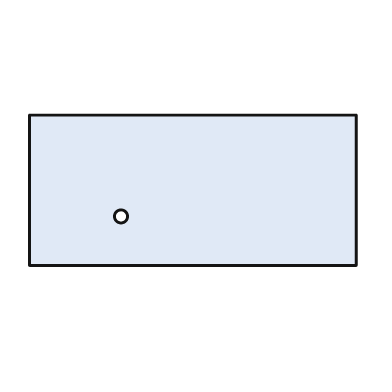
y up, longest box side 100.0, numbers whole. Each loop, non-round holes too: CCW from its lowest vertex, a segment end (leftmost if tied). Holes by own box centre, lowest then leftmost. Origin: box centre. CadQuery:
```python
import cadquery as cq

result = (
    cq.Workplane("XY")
    .moveTo(-50.0, -23.0)
    .lineTo(50.0, -23.0)
    .lineTo(50.0, 23.0)
    .lineTo(-50.0, 23.0)
    .close()
    .moveTo(-22.0, -8.0)
    .circle(2.0)
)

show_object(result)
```